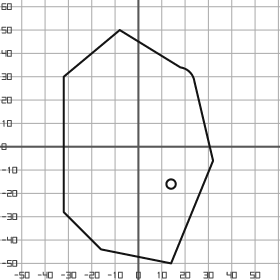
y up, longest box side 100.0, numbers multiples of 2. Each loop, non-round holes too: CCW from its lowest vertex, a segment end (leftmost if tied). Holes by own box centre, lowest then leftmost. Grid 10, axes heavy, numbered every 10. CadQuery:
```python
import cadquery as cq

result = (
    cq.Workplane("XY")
    .moveTo(14.0, -50.0)
    .lineTo(32.0, -6.0)
    .lineTo(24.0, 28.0)
    .threePointArc((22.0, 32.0), (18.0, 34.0))
    .lineTo(-8.0, 50.0)
    .lineTo(-32.0, 30.0)
    .lineTo(-32.0, -28.0)
    .lineTo(-16.0, -44.0)
    .close()
    .moveTo(14.0, -16.0)
    .circle(2.0)
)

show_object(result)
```